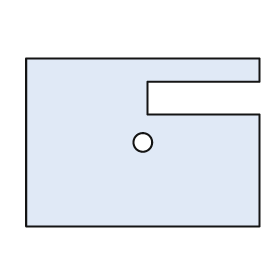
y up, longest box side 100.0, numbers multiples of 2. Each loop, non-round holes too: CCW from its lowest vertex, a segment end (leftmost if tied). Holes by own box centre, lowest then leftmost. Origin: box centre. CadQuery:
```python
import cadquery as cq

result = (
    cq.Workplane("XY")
    .moveTo(-50.0, -36.0)
    .lineTo(50.0, -36.0)
    .lineTo(50.0, 12.0)
    .lineTo(2.0, 12.0)
    .lineTo(2.0, 26.0)
    .lineTo(50.0, 26.0)
    .lineTo(50.0, 36.0)
    .lineTo(-50.0, 36.0)
    .close()
    .moveTo(0.0, 0.0)
    .circle(4.0)
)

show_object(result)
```